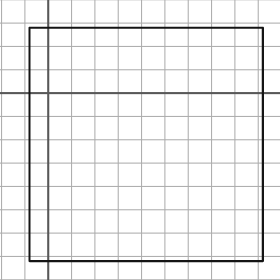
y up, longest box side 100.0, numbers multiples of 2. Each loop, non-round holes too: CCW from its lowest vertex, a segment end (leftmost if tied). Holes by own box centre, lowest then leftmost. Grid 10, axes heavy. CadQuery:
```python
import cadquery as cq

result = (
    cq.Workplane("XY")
    .moveTo(-8.0, -72.0)
    .lineTo(92.0, -72.0)
    .lineTo(92.0, 28.0)
    .lineTo(-8.0, 28.0)
    .close()
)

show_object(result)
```